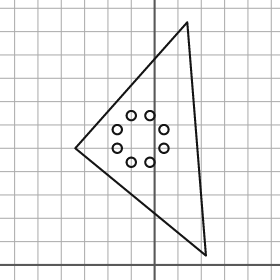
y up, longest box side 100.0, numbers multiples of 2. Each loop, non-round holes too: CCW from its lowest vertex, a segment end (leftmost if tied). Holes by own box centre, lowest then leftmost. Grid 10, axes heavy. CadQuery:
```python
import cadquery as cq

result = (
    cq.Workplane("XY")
    .moveTo(22.0, 4.0)
    .lineTo(14.0, 104.0)
    .lineTo(-34.0, 50.0)
    .close()
    .moveTo(-10.0, 44.0)
    .circle(2.0)
    .moveTo(-2.0, 44.0)
    .circle(2.0)
    .moveTo(-16.0, 50.0)
    .circle(2.0)
    .moveTo(4.0, 50.0)
    .circle(2.0)
    .moveTo(-16.0, 58.0)
    .circle(2.0)
    .moveTo(4.0, 58.0)
    .circle(2.0)
    .moveTo(-10.0, 64.0)
    .circle(2.0)
    .moveTo(-2.0, 64.0)
    .circle(2.0)
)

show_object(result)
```